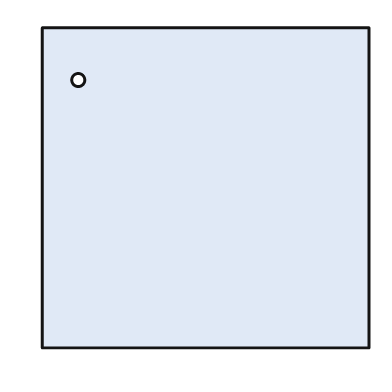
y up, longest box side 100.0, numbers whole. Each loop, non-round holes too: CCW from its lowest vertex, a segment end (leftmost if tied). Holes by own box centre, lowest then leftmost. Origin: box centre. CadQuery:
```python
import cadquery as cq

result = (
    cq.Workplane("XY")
    .moveTo(-50.0, -49.0)
    .lineTo(50.0, -49.0)
    .lineTo(50.0, 49.0)
    .lineTo(-50.0, 49.0)
    .close()
    .moveTo(-39.0, 33.0)
    .circle(2.0)
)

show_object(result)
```